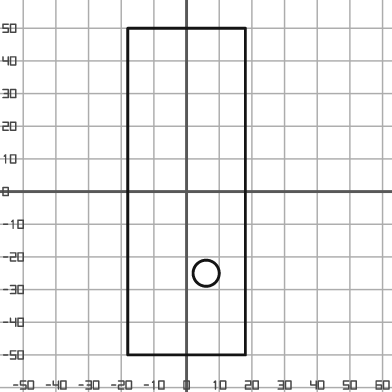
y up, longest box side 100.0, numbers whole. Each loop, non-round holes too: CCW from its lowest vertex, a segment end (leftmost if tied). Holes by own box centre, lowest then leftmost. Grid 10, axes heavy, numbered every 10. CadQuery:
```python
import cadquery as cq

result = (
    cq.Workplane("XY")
    .moveTo(-18.0, -50.0)
    .lineTo(18.0, -50.0)
    .lineTo(18.0, 50.0)
    .lineTo(-18.0, 50.0)
    .close()
    .moveTo(6.0, -25.0)
    .circle(4.0)
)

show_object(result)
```